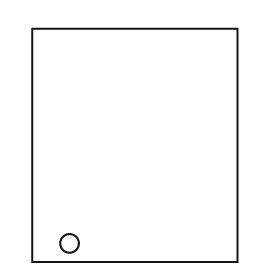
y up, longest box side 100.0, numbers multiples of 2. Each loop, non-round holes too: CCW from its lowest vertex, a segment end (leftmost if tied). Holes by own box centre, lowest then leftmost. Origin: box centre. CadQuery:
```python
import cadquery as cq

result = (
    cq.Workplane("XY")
    .moveTo(-44.0, -50.0)
    .lineTo(44.0, -50.0)
    .lineTo(44.0, 50.0)
    .lineTo(-44.0, 50.0)
    .close()
    .moveTo(-28.0, -42.0)
    .circle(4.0)
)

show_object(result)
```